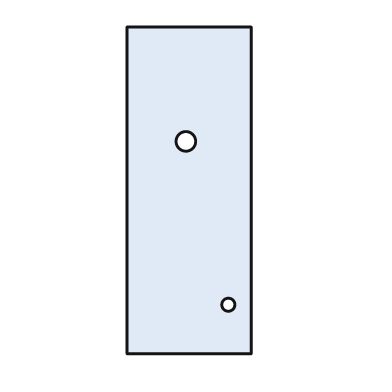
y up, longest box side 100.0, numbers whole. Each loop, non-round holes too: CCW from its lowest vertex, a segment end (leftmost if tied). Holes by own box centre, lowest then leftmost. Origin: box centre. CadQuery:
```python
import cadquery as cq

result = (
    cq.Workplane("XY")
    .moveTo(-19.0, -50.0)
    .lineTo(19.0, -50.0)
    .lineTo(19.0, 50.0)
    .lineTo(-19.0, 50.0)
    .close()
    .moveTo(12.0, -35.0)
    .circle(2.0)
    .moveTo(-1.0, 15.0)
    .circle(3.0)
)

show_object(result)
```